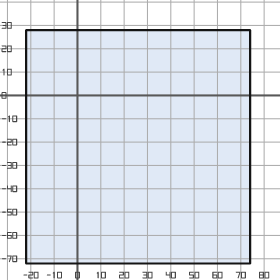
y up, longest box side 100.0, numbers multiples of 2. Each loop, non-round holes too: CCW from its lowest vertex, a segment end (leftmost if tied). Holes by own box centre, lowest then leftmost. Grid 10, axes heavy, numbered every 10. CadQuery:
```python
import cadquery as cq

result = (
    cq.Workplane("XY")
    .moveTo(-22.0, -72.0)
    .lineTo(74.0, -72.0)
    .lineTo(74.0, 28.0)
    .lineTo(-22.0, 28.0)
    .close()
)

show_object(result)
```